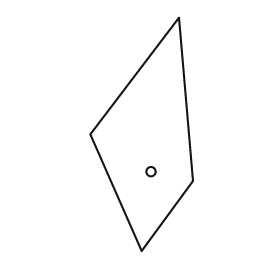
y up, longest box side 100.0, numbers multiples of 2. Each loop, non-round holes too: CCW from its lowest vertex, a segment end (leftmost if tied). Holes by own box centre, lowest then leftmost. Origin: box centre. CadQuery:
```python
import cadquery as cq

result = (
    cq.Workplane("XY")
    .moveTo(0.0, -50.0)
    .lineTo(22.0, -20.0)
    .lineTo(16.0, 50.0)
    .lineTo(-22.0, 0.0)
    .close()
    .moveTo(4.0, -16.0)
    .circle(2.0)
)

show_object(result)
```